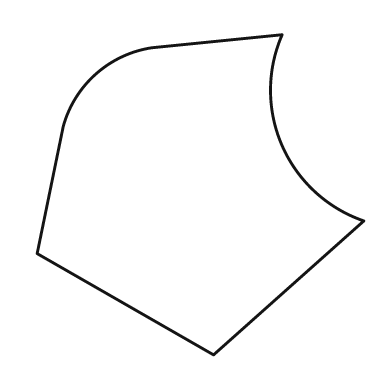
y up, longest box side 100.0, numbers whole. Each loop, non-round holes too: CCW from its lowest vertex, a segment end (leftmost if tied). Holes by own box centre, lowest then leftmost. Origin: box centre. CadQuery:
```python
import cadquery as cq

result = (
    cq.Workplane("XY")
    .moveTo(4.0, -49.0)
    .lineTo(50.0, -8.0)
    .threePointArc((25.0, 15.0), (25.0, 49.0))
    .lineTo(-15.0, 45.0)
    .threePointArc((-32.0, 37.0), (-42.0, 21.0))
    .lineTo(-50.0, -18.0)
    .close()
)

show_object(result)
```